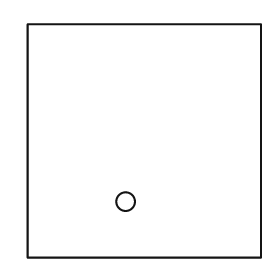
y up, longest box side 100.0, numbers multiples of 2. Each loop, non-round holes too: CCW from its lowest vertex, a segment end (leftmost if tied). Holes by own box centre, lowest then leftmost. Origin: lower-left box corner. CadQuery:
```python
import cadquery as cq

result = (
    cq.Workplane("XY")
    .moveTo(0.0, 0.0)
    .lineTo(100.0, 0.0)
    .lineTo(100.0, 100.0)
    .lineTo(0.0, 100.0)
    .close()
    .moveTo(42.0, 24.0)
    .circle(4.0)
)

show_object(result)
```